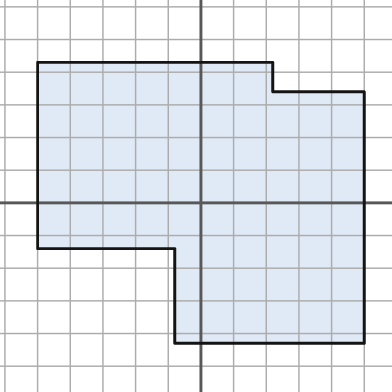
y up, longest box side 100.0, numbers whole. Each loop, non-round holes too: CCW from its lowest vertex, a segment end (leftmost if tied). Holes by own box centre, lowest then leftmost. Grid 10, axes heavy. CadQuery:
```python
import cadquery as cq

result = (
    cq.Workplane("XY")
    .moveTo(-8.0, -43.0)
    .lineTo(50.0, -43.0)
    .lineTo(50.0, 34.0)
    .lineTo(22.0, 34.0)
    .lineTo(22.0, 43.0)
    .lineTo(-50.0, 43.0)
    .lineTo(-50.0, -14.0)
    .lineTo(-8.0, -14.0)
    .close()
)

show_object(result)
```